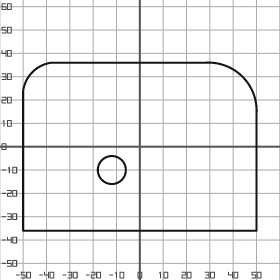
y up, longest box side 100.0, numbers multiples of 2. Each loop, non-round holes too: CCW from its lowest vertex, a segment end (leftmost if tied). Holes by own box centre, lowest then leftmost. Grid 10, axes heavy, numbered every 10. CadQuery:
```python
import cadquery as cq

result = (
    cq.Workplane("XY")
    .moveTo(-50.0, -36.0)
    .lineTo(50.0, -36.0)
    .lineTo(50.0, 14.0)
    .threePointArc((44.0, 30.0), (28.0, 36.0))
    .lineTo(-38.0, 36.0)
    .threePointArc((-46.0, 32.0), (-50.0, 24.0))
    .close()
    .moveTo(-12.0, -10.0)
    .circle(6.0)
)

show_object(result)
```